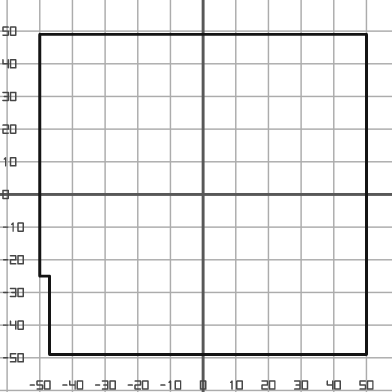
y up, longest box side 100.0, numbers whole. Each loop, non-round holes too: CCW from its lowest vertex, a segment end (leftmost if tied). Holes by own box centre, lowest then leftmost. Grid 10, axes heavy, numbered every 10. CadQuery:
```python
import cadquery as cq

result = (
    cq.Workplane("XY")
    .moveTo(-47.0, -49.0)
    .lineTo(50.0, -49.0)
    .lineTo(50.0, 49.0)
    .lineTo(-50.0, 49.0)
    .lineTo(-50.0, -25.0)
    .lineTo(-47.0, -25.0)
    .close()
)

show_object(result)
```